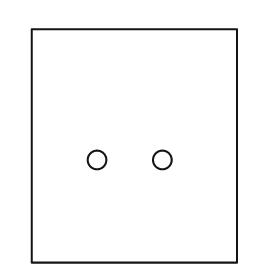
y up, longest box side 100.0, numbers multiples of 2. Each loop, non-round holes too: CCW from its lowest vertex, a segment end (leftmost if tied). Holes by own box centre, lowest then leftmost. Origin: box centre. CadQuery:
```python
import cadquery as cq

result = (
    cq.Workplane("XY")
    .moveTo(-44.0, -50.0)
    .lineTo(44.0, -50.0)
    .lineTo(44.0, 50.0)
    .lineTo(-44.0, 50.0)
    .close()
    .moveTo(-16.0, -6.0)
    .circle(4.0)
    .moveTo(12.0, -6.0)
    .circle(4.0)
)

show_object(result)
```